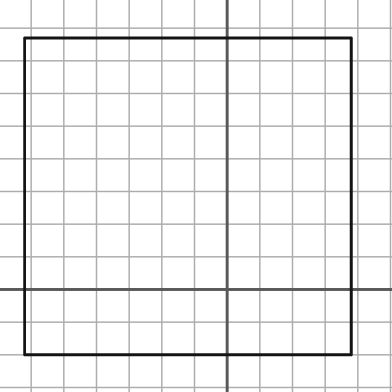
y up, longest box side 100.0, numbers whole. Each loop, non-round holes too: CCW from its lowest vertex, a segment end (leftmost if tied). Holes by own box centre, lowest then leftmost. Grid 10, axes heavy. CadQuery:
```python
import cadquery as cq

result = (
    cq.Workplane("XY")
    .moveTo(-62.0, -20.0)
    .lineTo(38.0, -20.0)
    .lineTo(38.0, 77.0)
    .lineTo(-62.0, 77.0)
    .close()
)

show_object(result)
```